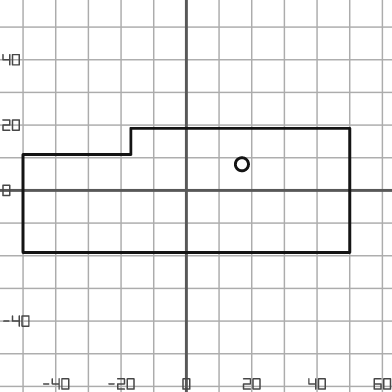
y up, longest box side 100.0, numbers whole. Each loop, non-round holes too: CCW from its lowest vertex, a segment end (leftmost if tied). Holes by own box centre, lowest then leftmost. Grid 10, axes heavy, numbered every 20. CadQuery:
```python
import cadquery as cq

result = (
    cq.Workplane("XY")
    .moveTo(-50.0, -19.0)
    .lineTo(50.0, -19.0)
    .lineTo(50.0, 19.0)
    .lineTo(-17.0, 19.0)
    .lineTo(-17.0, 11.0)
    .lineTo(-50.0, 11.0)
    .close()
    .moveTo(17.0, 8.0)
    .circle(2.0)
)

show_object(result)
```